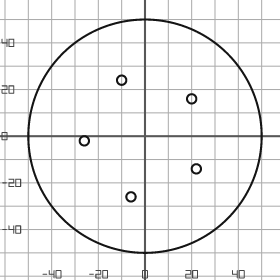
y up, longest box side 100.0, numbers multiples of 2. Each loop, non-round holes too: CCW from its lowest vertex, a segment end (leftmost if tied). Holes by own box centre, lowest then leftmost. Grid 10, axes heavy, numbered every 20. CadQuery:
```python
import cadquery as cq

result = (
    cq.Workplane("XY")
    .moveTo(0.0, 0.0)
    .circle(50.0)
    .moveTo(-6.0, -26.0)
    .circle(2.0)
    .moveTo(22.0, -14.0)
    .circle(2.0)
    .moveTo(-26.0, -2.0)
    .circle(2.0)
    .moveTo(20.0, 16.0)
    .circle(2.0)
    .moveTo(-10.0, 24.0)
    .circle(2.0)
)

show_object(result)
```